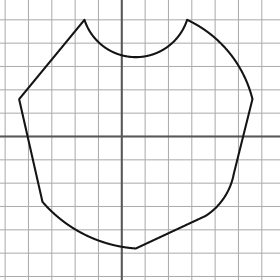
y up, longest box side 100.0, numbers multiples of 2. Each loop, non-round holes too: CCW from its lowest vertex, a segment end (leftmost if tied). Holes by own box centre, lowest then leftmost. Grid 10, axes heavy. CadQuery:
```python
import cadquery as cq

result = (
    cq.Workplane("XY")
    .moveTo(6.0, -48.0)
    .lineTo(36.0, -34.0)
    .threePointArc((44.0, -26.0), (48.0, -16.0))
    .lineTo(56.0, 16.0)
    .threePointArc((46.0, 36.0), (28.0, 50.0))
    .threePointArc((6.0, 34.0), (-16.0, 50.0))
    .lineTo(-44.0, 16.0)
    .lineTo(-34.0, -28.0)
    .threePointArc((-16.0, -42.0), (6.0, -48.0))
    .close()
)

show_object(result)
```